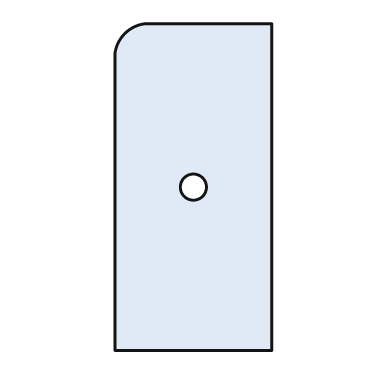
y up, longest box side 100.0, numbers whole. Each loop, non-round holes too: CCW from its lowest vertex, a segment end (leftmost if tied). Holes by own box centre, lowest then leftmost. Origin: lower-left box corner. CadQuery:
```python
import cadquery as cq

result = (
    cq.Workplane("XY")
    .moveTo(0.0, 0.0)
    .lineTo(48.0, 0.0)
    .lineTo(48.0, 100.0)
    .lineTo(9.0, 100.0)
    .threePointArc((3.0, 97.0), (0.0, 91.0))
    .close()
    .moveTo(24.0, 50.0)
    .circle(4.0)
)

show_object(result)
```